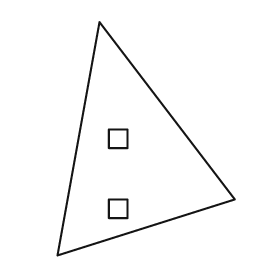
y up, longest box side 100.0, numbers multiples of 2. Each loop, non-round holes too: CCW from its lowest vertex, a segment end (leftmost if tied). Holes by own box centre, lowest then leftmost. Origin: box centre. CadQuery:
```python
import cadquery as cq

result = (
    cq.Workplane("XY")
    .moveTo(-38.0, -50.0)
    .lineTo(38.0, -26.0)
    .lineTo(-20.0, 50.0)
    .close()
    .moveTo(-16.0, -34.0)
    .lineTo(-8.0, -34.0)
    .lineTo(-8.0, -26.0)
    .lineTo(-16.0, -26.0)
    .close()
    .moveTo(-16.0, -4.0)
    .lineTo(-8.0, -4.0)
    .lineTo(-8.0, 4.0)
    .lineTo(-16.0, 4.0)
    .close()
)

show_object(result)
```